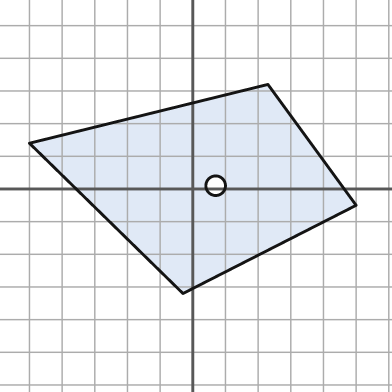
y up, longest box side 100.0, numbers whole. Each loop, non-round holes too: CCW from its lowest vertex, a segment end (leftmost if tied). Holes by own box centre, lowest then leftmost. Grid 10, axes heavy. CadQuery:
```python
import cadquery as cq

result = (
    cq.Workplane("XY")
    .moveTo(-3.0, -32.0)
    .lineTo(50.0, -5.0)
    .lineTo(23.0, 32.0)
    .lineTo(-50.0, 14.0)
    .close()
    .moveTo(7.0, 1.0)
    .circle(3.0)
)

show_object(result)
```